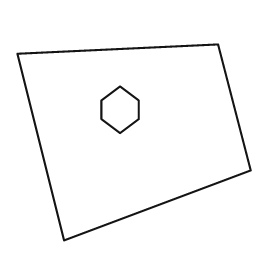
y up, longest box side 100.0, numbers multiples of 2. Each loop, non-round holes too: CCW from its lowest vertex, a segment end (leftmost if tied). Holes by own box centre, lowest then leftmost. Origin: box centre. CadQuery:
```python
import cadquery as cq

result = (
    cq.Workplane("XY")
    .moveTo(-30.0, -42.0)
    .lineTo(50.0, -12.0)
    .lineTo(36.0, 42.0)
    .lineTo(-50.0, 38.0)
    .close()
    .moveTo(-6.0, 4.0)
    .lineTo(2.0, 10.0)
    .lineTo(2.0, 18.0)
    .lineTo(-6.0, 24.0)
    .lineTo(-14.0, 18.0)
    .lineTo(-14.0, 10.0)
    .close()
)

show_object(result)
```